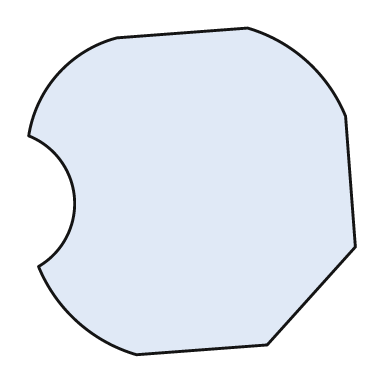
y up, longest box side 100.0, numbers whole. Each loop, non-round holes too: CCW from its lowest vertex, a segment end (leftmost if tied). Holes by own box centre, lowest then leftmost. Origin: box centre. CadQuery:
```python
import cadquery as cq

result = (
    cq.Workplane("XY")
    .moveTo(-17.0, -50.0)
    .lineTo(23.0, -47.0)
    .lineTo(50.0, -17.0)
    .lineTo(47.0, 23.0)
    .threePointArc((35.0, 40.0), (17.0, 50.0))
    .lineTo(-23.0, 47.0)
    .threePointArc((-41.0, 36.0), (-50.0, 17.0))
    .threePointArc((-36.0, -2.0), (-47.0, -23.0))
    .threePointArc((-35.0, -40.0), (-17.0, -50.0))
    .close()
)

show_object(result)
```